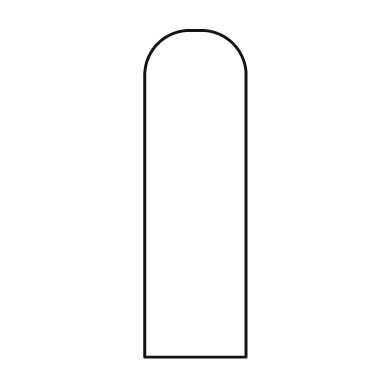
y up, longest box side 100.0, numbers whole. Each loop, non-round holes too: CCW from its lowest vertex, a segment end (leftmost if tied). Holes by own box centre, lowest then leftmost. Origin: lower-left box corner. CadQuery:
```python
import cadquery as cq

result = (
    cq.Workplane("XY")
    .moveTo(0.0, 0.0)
    .lineTo(31.0, 0.0)
    .lineTo(31.0, 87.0)
    .threePointArc((27.0, 96.0), (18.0, 100.0))
    .lineTo(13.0, 100.0)
    .threePointArc((4.0, 96.0), (0.0, 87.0))
    .close()
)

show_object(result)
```